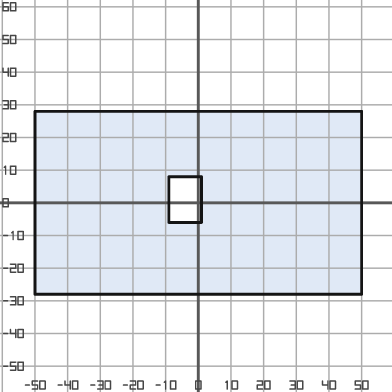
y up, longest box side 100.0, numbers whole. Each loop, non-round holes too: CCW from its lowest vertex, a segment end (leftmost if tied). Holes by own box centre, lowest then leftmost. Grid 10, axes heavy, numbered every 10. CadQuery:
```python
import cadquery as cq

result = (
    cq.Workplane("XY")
    .moveTo(-50.0, -28.0)
    .lineTo(50.0, -28.0)
    .lineTo(50.0, 28.0)
    .lineTo(-50.0, 28.0)
    .close()
    .moveTo(-9.0, -6.0)
    .lineTo(1.0, -6.0)
    .lineTo(1.0, 8.0)
    .lineTo(-9.0, 8.0)
    .close()
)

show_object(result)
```